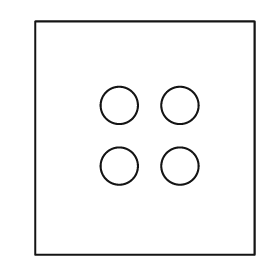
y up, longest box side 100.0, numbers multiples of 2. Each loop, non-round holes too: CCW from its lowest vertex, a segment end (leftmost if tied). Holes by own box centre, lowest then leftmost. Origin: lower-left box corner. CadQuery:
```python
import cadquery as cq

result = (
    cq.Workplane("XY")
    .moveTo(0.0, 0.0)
    .lineTo(94.0, 0.0)
    .lineTo(94.0, 100.0)
    .lineTo(0.0, 100.0)
    .close()
    .moveTo(36.0, 38.0)
    .circle(8.0)
    .moveTo(62.0, 38.0)
    .circle(8.0)
    .moveTo(36.0, 64.0)
    .circle(8.0)
    .moveTo(62.0, 64.0)
    .circle(8.0)
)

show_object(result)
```